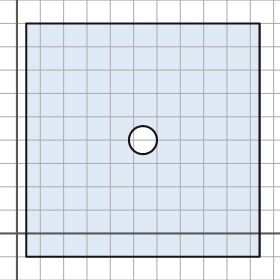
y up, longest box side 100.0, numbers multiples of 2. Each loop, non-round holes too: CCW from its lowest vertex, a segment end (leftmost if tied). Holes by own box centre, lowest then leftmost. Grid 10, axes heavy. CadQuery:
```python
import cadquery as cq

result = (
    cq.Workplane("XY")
    .moveTo(4.0, -10.0)
    .lineTo(104.0, -10.0)
    .lineTo(104.0, 90.0)
    .lineTo(4.0, 90.0)
    .close()
    .moveTo(54.0, 40.0)
    .circle(6.0)
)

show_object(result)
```